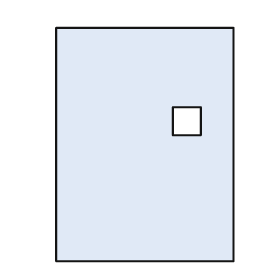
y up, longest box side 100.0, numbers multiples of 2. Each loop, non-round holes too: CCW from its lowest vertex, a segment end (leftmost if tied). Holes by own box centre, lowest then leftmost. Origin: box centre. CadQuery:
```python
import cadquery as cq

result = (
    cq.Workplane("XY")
    .moveTo(-38.0, -50.0)
    .lineTo(38.0, -50.0)
    .lineTo(38.0, 50.0)
    .lineTo(-38.0, 50.0)
    .close()
    .moveTo(12.0, 4.0)
    .lineTo(24.0, 4.0)
    .lineTo(24.0, 16.0)
    .lineTo(12.0, 16.0)
    .close()
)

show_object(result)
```